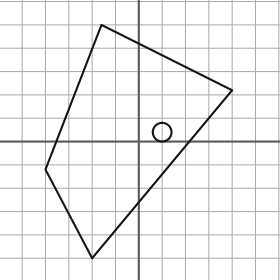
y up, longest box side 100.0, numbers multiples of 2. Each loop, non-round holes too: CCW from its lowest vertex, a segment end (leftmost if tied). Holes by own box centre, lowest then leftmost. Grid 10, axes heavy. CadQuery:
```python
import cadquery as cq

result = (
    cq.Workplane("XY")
    .moveTo(-20.0, -50.0)
    .lineTo(40.0, 22.0)
    .lineTo(-16.0, 50.0)
    .lineTo(-40.0, -12.0)
    .close()
    .moveTo(10.0, 4.0)
    .circle(4.0)
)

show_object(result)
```